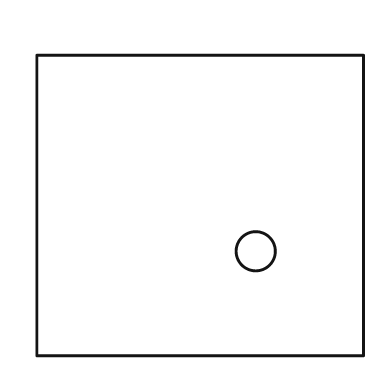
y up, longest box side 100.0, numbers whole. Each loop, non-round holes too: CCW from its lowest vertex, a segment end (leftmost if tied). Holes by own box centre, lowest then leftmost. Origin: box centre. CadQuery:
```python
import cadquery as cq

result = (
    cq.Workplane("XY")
    .moveTo(-50.0, -46.0)
    .lineTo(50.0, -46.0)
    .lineTo(50.0, 46.0)
    .lineTo(-50.0, 46.0)
    .close()
    .moveTo(17.0, -14.0)
    .circle(6.0)
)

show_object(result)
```